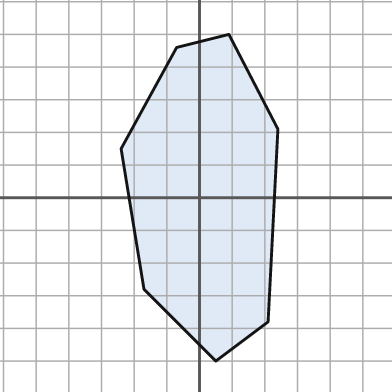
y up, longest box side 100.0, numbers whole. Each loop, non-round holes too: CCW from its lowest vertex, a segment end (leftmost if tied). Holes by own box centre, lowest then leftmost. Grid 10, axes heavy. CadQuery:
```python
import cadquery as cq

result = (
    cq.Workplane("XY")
    .moveTo(5.0, -50.0)
    .lineTo(21.0, -38.0)
    .lineTo(24.0, 21.0)
    .lineTo(9.0, 50.0)
    .lineTo(-7.0, 46.0)
    .lineTo(-24.0, 15.0)
    .lineTo(-17.0, -28.0)
    .close()
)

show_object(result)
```